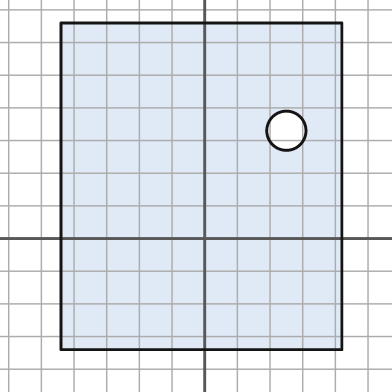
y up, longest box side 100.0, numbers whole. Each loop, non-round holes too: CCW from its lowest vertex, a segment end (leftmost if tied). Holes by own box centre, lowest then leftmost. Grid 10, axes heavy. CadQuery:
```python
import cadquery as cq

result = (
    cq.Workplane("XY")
    .moveTo(-44.0, -34.0)
    .lineTo(42.0, -34.0)
    .lineTo(42.0, 66.0)
    .lineTo(-44.0, 66.0)
    .close()
    .moveTo(25.0, 33.0)
    .circle(6.0)
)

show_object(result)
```